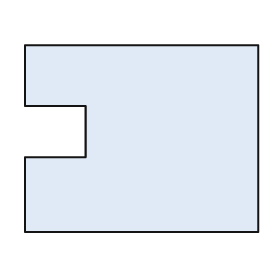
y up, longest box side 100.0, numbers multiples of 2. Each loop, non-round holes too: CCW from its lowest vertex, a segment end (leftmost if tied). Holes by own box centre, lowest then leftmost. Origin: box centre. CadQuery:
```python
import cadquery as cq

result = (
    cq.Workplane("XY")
    .moveTo(-50.0, -40.0)
    .lineTo(50.0, -40.0)
    .lineTo(50.0, 40.0)
    .lineTo(-50.0, 40.0)
    .lineTo(-50.0, 14.0)
    .lineTo(-24.0, 14.0)
    .lineTo(-24.0, -8.0)
    .lineTo(-50.0, -8.0)
    .close()
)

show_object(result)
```